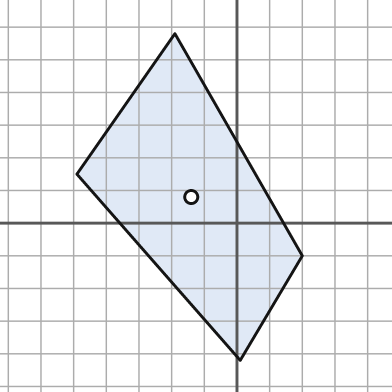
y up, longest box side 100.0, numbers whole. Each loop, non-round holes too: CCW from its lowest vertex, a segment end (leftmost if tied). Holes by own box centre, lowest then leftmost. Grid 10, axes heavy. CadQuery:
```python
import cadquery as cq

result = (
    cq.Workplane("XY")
    .moveTo(1.0, -42.0)
    .lineTo(20.0, -10.0)
    .lineTo(-19.0, 58.0)
    .lineTo(-49.0, 15.0)
    .close()
    .moveTo(-14.0, 8.0)
    .circle(2.0)
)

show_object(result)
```